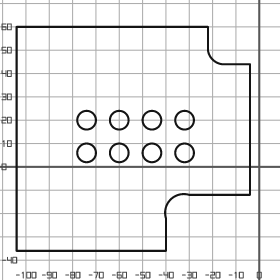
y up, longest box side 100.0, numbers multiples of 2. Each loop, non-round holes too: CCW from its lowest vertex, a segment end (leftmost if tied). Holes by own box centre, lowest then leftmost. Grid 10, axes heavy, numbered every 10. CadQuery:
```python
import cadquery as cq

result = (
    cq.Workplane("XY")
    .moveTo(-104.0, -36.0)
    .lineTo(-40.0, -36.0)
    .lineTo(-40.0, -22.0)
    .threePointArc((-38.0, -14.0), (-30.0, -12.0))
    .lineTo(-4.0, -12.0)
    .lineTo(-4.0, 44.0)
    .lineTo(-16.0, 44.0)
    .threePointArc((-20.0, 46.0), (-22.0, 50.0))
    .lineTo(-22.0, 60.0)
    .lineTo(-104.0, 60.0)
    .close()
    .moveTo(-74.0, 6.0)
    .circle(4.0)
    .moveTo(-60.0, 6.0)
    .circle(4.0)
    .moveTo(-46.0, 6.0)
    .circle(4.0)
    .moveTo(-32.0, 6.0)
    .circle(4.0)
    .moveTo(-74.0, 20.0)
    .circle(4.0)
    .moveTo(-60.0, 20.0)
    .circle(4.0)
    .moveTo(-46.0, 20.0)
    .circle(4.0)
    .moveTo(-32.0, 20.0)
    .circle(4.0)
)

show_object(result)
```